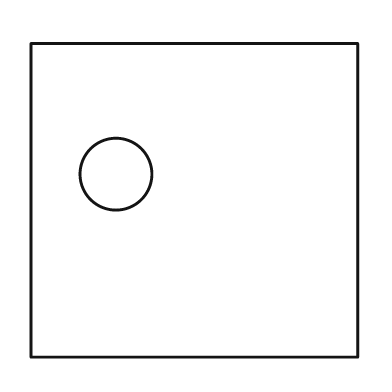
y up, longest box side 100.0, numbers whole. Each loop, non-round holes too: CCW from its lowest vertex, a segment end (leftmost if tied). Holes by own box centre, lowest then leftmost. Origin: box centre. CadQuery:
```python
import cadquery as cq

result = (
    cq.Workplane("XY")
    .moveTo(-50.0, -48.0)
    .lineTo(50.0, -48.0)
    .lineTo(50.0, 48.0)
    .lineTo(-50.0, 48.0)
    .close()
    .moveTo(-24.0, 8.0)
    .circle(11.0)
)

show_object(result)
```